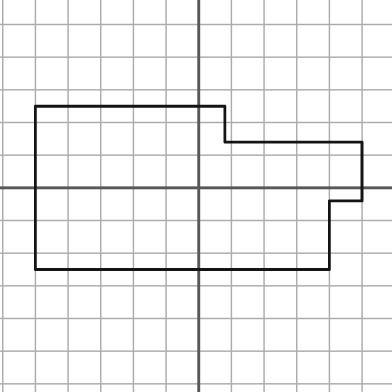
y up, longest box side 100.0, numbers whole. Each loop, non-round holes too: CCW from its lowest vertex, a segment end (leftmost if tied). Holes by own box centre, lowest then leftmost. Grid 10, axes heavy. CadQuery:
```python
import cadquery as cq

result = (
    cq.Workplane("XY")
    .moveTo(-50.0, -25.0)
    .lineTo(40.0, -25.0)
    .lineTo(40.0, -4.0)
    .lineTo(50.0, -4.0)
    .lineTo(50.0, 14.0)
    .lineTo(8.0, 14.0)
    .lineTo(8.0, 25.0)
    .lineTo(-50.0, 25.0)
    .close()
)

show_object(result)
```